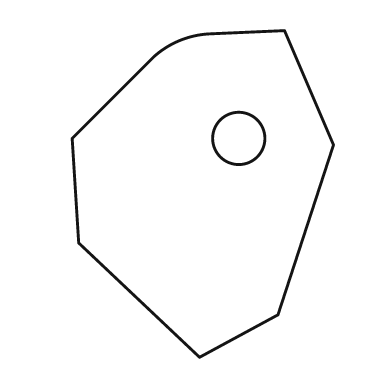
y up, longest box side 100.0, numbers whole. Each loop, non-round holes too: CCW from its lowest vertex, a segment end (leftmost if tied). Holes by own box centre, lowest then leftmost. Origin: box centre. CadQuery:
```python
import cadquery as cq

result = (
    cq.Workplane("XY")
    .moveTo(-1.0, -50.0)
    .lineTo(23.0, -37.0)
    .lineTo(40.0, 15.0)
    .lineTo(25.0, 50.0)
    .lineTo(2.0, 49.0)
    .threePointArc((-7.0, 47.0), (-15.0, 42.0))
    .lineTo(-40.0, 17.0)
    .lineTo(-38.0, -15.0)
    .close()
    .moveTo(11.0, 17.0)
    .circle(8.0)
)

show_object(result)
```